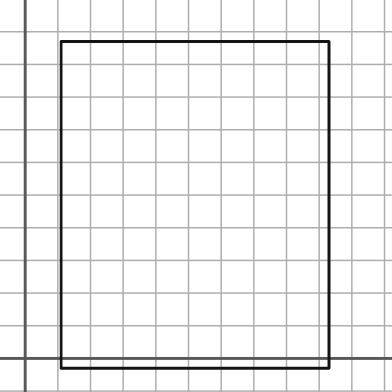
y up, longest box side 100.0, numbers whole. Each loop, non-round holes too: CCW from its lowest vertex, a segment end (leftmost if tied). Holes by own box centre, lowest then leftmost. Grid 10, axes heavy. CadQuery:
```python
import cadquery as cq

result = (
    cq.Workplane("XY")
    .moveTo(11.0, -3.0)
    .lineTo(93.0, -3.0)
    .lineTo(93.0, 97.0)
    .lineTo(11.0, 97.0)
    .close()
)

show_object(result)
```